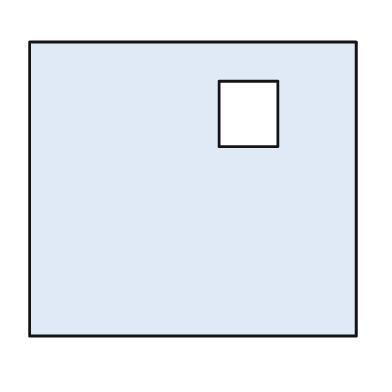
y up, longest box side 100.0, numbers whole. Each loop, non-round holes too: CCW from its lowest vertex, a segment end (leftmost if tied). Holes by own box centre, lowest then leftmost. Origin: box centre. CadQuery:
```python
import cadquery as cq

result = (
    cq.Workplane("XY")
    .moveTo(-50.0, -45.0)
    .lineTo(50.0, -45.0)
    .lineTo(50.0, 45.0)
    .lineTo(-50.0, 45.0)
    .close()
    .moveTo(8.0, 13.0)
    .lineTo(26.0, 13.0)
    .lineTo(26.0, 33.0)
    .lineTo(8.0, 33.0)
    .close()
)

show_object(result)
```